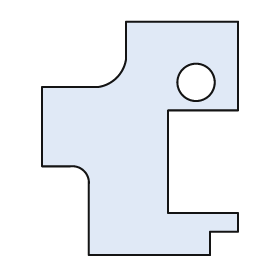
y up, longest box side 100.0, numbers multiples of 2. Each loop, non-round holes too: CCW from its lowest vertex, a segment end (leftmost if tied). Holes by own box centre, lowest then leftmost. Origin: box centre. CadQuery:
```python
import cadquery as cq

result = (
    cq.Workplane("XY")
    .moveTo(-22.0, -50.0)
    .lineTo(30.0, -50.0)
    .lineTo(30.0, -40.0)
    .lineTo(42.0, -40.0)
    .lineTo(42.0, -32.0)
    .lineTo(12.0, -32.0)
    .lineTo(12.0, 12.0)
    .lineTo(42.0, 12.0)
    .lineTo(42.0, 50.0)
    .lineTo(-6.0, 50.0)
    .lineTo(-6.0, 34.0)
    .threePointArc((-10.0, 26.0), (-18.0, 22.0))
    .lineTo(-42.0, 22.0)
    .lineTo(-42.0, -12.0)
    .lineTo(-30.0, -12.0)
    .threePointArc((-24.0, -14.0), (-22.0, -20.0))
    .close()
    .moveTo(24.0, 24.0)
    .circle(8.0)
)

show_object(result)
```